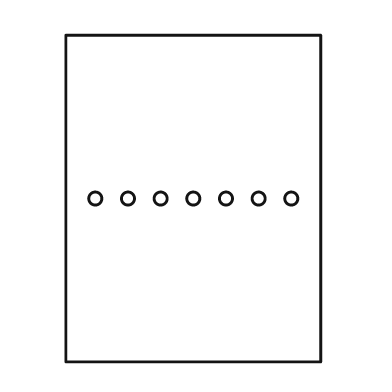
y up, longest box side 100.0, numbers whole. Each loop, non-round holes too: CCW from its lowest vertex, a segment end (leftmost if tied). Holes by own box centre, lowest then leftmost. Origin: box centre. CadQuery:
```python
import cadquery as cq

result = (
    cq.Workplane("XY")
    .moveTo(-39.0, -50.0)
    .lineTo(39.0, -50.0)
    .lineTo(39.0, 50.0)
    .lineTo(-39.0, 50.0)
    .close()
    .moveTo(-30.0, 0.0)
    .circle(2.0)
    .moveTo(-20.0, 0.0)
    .circle(2.0)
    .moveTo(-10.0, 0.0)
    .circle(2.0)
    .moveTo(0.0, 0.0)
    .circle(2.0)
    .moveTo(10.0, 0.0)
    .circle(2.0)
    .moveTo(20.0, 0.0)
    .circle(2.0)
    .moveTo(30.0, 0.0)
    .circle(2.0)
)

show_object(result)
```